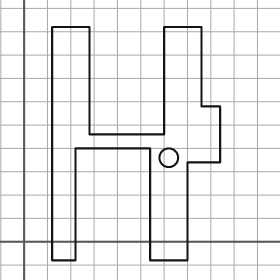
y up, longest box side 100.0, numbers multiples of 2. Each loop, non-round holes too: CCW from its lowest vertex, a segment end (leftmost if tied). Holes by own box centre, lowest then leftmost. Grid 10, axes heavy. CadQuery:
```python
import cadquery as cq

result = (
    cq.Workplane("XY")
    .moveTo(12.0, -8.0)
    .lineTo(22.0, -8.0)
    .lineTo(22.0, 40.0)
    .lineTo(54.0, 40.0)
    .lineTo(54.0, -8.0)
    .lineTo(70.0, -8.0)
    .lineTo(70.0, 34.0)
    .lineTo(84.0, 34.0)
    .lineTo(84.0, 58.0)
    .lineTo(76.0, 58.0)
    .lineTo(76.0, 92.0)
    .lineTo(60.0, 92.0)
    .lineTo(60.0, 46.0)
    .lineTo(28.0, 46.0)
    .lineTo(28.0, 92.0)
    .lineTo(12.0, 92.0)
    .close()
    .moveTo(62.0, 36.0)
    .circle(4.0)
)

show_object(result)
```